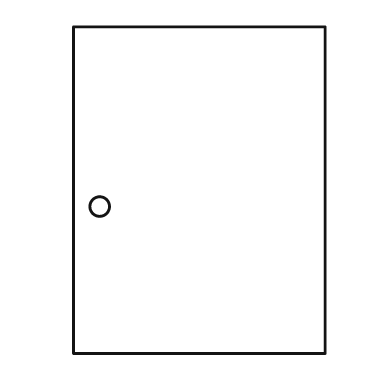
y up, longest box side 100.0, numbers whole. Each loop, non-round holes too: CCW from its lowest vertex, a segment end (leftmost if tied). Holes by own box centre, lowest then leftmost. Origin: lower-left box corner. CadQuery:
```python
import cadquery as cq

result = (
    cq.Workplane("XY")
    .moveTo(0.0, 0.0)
    .lineTo(77.0, 0.0)
    .lineTo(77.0, 100.0)
    .lineTo(0.0, 100.0)
    .close()
    .moveTo(8.0, 45.0)
    .circle(3.0)
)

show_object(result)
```